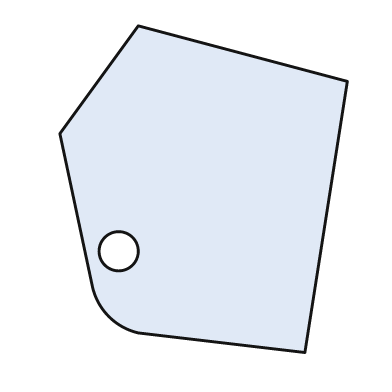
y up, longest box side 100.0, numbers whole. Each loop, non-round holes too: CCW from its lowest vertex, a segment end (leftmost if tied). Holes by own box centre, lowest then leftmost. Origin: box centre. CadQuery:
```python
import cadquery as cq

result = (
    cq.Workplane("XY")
    .moveTo(31.0, -50.0)
    .lineTo(44.0, 33.0)
    .lineTo(-20.0, 50.0)
    .lineTo(-44.0, 17.0)
    .lineTo(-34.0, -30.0)
    .threePointArc((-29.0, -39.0), (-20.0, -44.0))
    .close()
    .moveTo(-26.0, -19.0)
    .circle(6.0)
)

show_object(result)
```